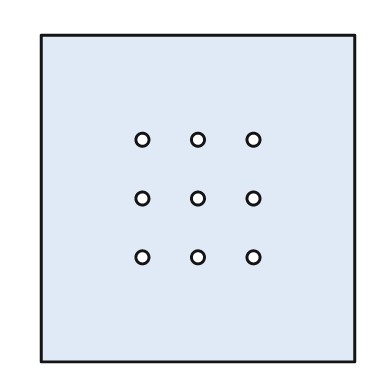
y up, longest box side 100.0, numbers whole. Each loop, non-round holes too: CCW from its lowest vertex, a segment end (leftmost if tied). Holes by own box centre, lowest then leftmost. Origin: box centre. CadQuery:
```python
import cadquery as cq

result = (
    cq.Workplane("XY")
    .moveTo(-48.0, -50.0)
    .lineTo(48.0, -50.0)
    .lineTo(48.0, 50.0)
    .lineTo(-48.0, 50.0)
    .close()
    .moveTo(-17.0, -18.0)
    .circle(2.0)
    .moveTo(0.0, -18.0)
    .circle(2.0)
    .moveTo(17.0, -18.0)
    .circle(2.0)
    .moveTo(-17.0, 0.0)
    .circle(2.0)
    .moveTo(0.0, 0.0)
    .circle(2.0)
    .moveTo(17.0, 0.0)
    .circle(2.0)
    .moveTo(-17.0, 18.0)
    .circle(2.0)
    .moveTo(0.0, 18.0)
    .circle(2.0)
    .moveTo(17.0, 18.0)
    .circle(2.0)
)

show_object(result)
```